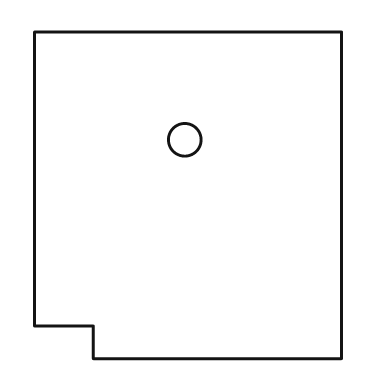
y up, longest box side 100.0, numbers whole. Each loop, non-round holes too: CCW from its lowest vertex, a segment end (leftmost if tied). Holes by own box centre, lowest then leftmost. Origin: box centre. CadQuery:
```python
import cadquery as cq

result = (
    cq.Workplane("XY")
    .moveTo(-29.0, -50.0)
    .lineTo(47.0, -50.0)
    .lineTo(47.0, 50.0)
    .lineTo(-47.0, 50.0)
    .lineTo(-47.0, -40.0)
    .lineTo(-29.0, -40.0)
    .close()
    .moveTo(-1.0, 17.0)
    .circle(5.0)
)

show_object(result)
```